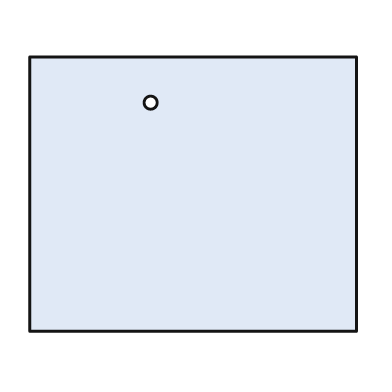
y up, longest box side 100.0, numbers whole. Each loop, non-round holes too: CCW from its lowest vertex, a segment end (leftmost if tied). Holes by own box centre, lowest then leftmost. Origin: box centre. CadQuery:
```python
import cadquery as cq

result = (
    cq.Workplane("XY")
    .moveTo(-50.0, -42.0)
    .lineTo(50.0, -42.0)
    .lineTo(50.0, 42.0)
    .lineTo(-50.0, 42.0)
    .close()
    .moveTo(-13.0, 28.0)
    .circle(2.0)
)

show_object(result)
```